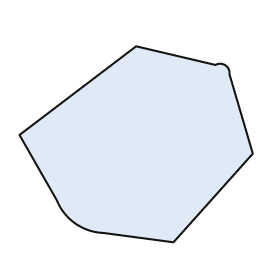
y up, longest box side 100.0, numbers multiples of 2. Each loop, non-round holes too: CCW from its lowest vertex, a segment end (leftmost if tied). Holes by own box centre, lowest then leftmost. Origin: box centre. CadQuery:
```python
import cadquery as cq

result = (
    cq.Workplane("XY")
    .moveTo(16.0, -42.0)
    .lineTo(50.0, -4.0)
    .lineTo(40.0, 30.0)
    .threePointArc((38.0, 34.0), (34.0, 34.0))
    .lineTo(0.0, 42.0)
    .lineTo(-50.0, 4.0)
    .lineTo(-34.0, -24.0)
    .threePointArc((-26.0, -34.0), (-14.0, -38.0))
    .close()
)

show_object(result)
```